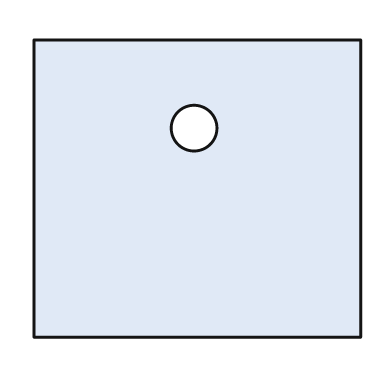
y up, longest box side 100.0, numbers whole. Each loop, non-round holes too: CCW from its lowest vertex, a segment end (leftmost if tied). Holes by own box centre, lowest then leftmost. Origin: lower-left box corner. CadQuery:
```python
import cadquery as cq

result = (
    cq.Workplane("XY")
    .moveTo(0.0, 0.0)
    .lineTo(100.0, 0.0)
    .lineTo(100.0, 91.0)
    .lineTo(0.0, 91.0)
    .close()
    .moveTo(49.0, 64.0)
    .circle(7.0)
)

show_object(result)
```